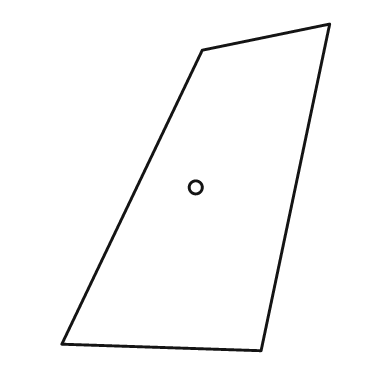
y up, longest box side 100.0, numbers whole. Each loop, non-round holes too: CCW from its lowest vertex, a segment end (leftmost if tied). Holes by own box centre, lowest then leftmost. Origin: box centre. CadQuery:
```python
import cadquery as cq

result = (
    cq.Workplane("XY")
    .moveTo(20.0, -50.0)
    .lineTo(41.0, 50.0)
    .lineTo(2.0, 42.0)
    .lineTo(-41.0, -48.0)
    .close()
    .moveTo(0.0, 0.0)
    .circle(2.0)
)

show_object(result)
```